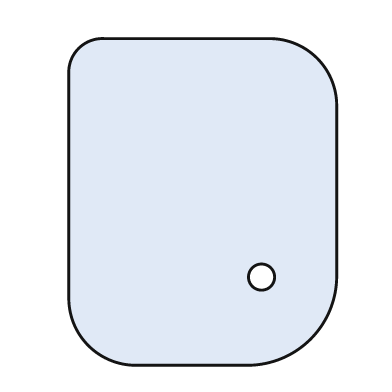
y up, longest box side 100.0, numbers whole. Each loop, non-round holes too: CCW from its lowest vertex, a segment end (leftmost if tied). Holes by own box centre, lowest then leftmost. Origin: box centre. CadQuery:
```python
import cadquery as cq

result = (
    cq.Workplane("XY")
    .moveTo(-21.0, -50.0)
    .lineTo(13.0, -50.0)
    .threePointArc((33.0, -42.0), (41.0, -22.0))
    .lineTo(41.0, 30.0)
    .threePointArc((35.0, 44.0), (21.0, 50.0))
    .lineTo(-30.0, 50.0)
    .threePointArc((-38.0, 47.0), (-41.0, 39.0))
    .lineTo(-41.0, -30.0)
    .threePointArc((-35.0, -44.0), (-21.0, -50.0))
    .close()
    .moveTo(18.0, -23.0)
    .circle(4.0)
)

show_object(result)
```